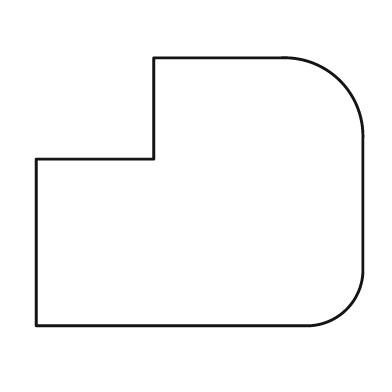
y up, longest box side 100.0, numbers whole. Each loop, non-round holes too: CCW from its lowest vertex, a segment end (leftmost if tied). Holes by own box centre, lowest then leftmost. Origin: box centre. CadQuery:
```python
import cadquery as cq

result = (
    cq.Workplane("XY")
    .moveTo(-50.0, -41.0)
    .lineTo(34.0, -41.0)
    .threePointArc((45.0, -36.0), (50.0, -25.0))
    .lineTo(50.0, 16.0)
    .threePointArc((43.0, 34.0), (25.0, 41.0))
    .lineTo(-14.0, 41.0)
    .lineTo(-14.0, 10.0)
    .lineTo(-50.0, 10.0)
    .close()
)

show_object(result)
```